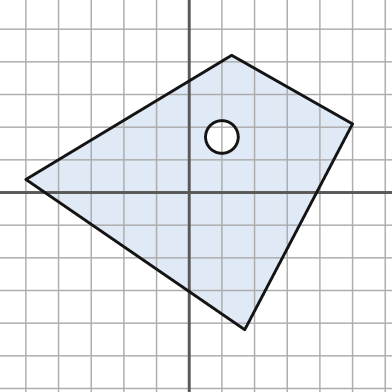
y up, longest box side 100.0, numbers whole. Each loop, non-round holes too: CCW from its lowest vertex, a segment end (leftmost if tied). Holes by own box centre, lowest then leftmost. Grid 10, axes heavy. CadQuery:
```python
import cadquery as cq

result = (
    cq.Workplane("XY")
    .moveTo(17.0, -42.0)
    .lineTo(50.0, 21.0)
    .lineTo(13.0, 42.0)
    .lineTo(-50.0, 4.0)
    .close()
    .moveTo(10.0, 17.0)
    .circle(5.0)
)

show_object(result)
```